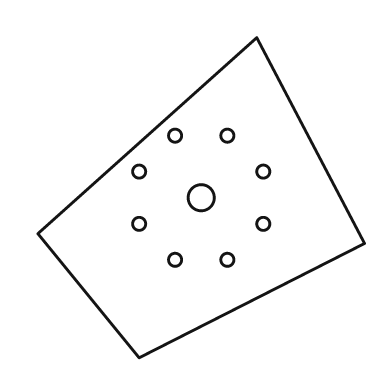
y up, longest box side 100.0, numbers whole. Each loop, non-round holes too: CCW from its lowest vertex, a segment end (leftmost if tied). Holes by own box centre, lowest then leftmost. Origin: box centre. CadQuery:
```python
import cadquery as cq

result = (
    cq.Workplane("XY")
    .moveTo(-19.0, -49.0)
    .lineTo(50.0, -14.0)
    .lineTo(17.0, 49.0)
    .lineTo(-50.0, -11.0)
    .close()
    .moveTo(-8.0, -19.0)
    .circle(2.0)
    .moveTo(8.0, -19.0)
    .circle(2.0)
    .moveTo(-19.0, -8.0)
    .circle(2.0)
    .moveTo(19.0, -8.0)
    .circle(2.0)
    .moveTo(0.0, 0.0)
    .circle(4.0)
    .moveTo(-19.0, 8.0)
    .circle(2.0)
    .moveTo(19.0, 8.0)
    .circle(2.0)
    .moveTo(-8.0, 19.0)
    .circle(2.0)
    .moveTo(8.0, 19.0)
    .circle(2.0)
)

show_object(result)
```